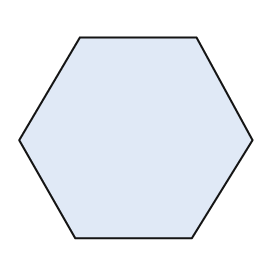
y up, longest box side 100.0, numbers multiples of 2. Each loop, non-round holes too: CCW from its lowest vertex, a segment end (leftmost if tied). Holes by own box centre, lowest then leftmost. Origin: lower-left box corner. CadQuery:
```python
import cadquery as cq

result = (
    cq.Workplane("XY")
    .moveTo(24.0, 0.0)
    .lineTo(74.0, 0.0)
    .lineTo(100.0, 42.0)
    .lineTo(76.0, 86.0)
    .lineTo(26.0, 86.0)
    .lineTo(0.0, 42.0)
    .close()
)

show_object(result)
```